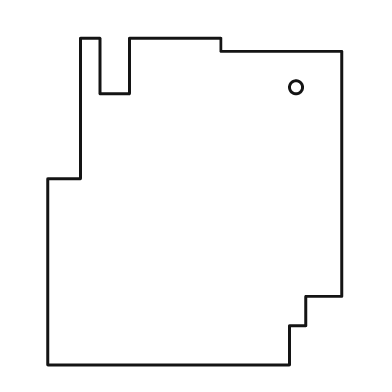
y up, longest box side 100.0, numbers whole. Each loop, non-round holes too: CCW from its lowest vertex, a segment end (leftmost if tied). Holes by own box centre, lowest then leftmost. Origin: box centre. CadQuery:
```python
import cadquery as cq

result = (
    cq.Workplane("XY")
    .moveTo(-45.0, -50.0)
    .lineTo(29.0, -50.0)
    .lineTo(29.0, -38.0)
    .lineTo(34.0, -38.0)
    .lineTo(34.0, -29.0)
    .lineTo(45.0, -29.0)
    .lineTo(45.0, 46.0)
    .lineTo(8.0, 46.0)
    .lineTo(8.0, 50.0)
    .lineTo(-20.0, 50.0)
    .lineTo(-20.0, 33.0)
    .lineTo(-29.0, 33.0)
    .lineTo(-29.0, 50.0)
    .lineTo(-35.0, 50.0)
    .lineTo(-35.0, 7.0)
    .lineTo(-45.0, 7.0)
    .close()
    .moveTo(31.0, 35.0)
    .circle(2.0)
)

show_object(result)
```